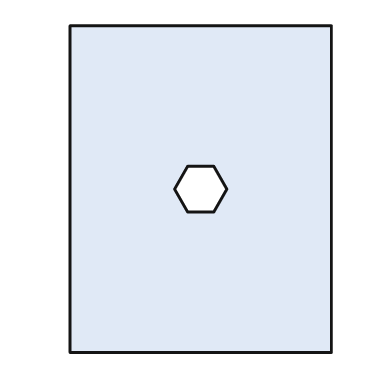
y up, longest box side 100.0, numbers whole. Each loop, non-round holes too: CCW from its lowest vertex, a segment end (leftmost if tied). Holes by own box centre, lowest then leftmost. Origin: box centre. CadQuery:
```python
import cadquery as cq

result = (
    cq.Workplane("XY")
    .moveTo(-40.0, -50.0)
    .lineTo(40.0, -50.0)
    .lineTo(40.0, 50.0)
    .lineTo(-40.0, 50.0)
    .close()
    .moveTo(-4.0, -7.0)
    .lineTo(4.0, -7.0)
    .lineTo(8.0, 0.0)
    .lineTo(4.0, 7.0)
    .lineTo(-4.0, 7.0)
    .lineTo(-8.0, 0.0)
    .close()
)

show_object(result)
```